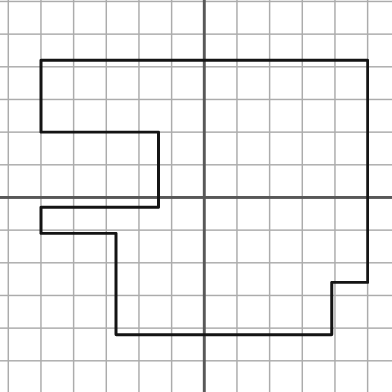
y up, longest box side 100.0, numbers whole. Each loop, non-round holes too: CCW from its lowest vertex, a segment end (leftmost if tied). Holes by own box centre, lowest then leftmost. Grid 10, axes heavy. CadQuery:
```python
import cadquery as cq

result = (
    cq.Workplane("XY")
    .moveTo(-27.0, -42.0)
    .lineTo(39.0, -42.0)
    .lineTo(39.0, -26.0)
    .lineTo(50.0, -26.0)
    .lineTo(50.0, 42.0)
    .lineTo(-50.0, 42.0)
    .lineTo(-50.0, 20.0)
    .lineTo(-14.0, 20.0)
    .lineTo(-14.0, -3.0)
    .lineTo(-50.0, -3.0)
    .lineTo(-50.0, -11.0)
    .lineTo(-27.0, -11.0)
    .close()
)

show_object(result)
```